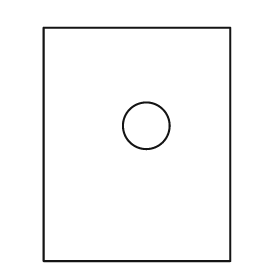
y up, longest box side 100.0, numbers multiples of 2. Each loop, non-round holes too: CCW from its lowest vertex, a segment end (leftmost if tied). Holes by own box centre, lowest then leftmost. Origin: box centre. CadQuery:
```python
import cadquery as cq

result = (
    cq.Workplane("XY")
    .moveTo(-40.0, -50.0)
    .lineTo(40.0, -50.0)
    .lineTo(40.0, 50.0)
    .lineTo(-40.0, 50.0)
    .close()
    .moveTo(4.0, 8.0)
    .circle(10.0)
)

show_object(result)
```